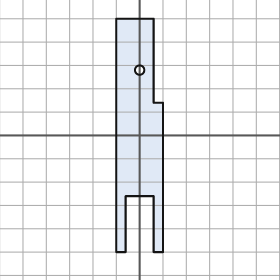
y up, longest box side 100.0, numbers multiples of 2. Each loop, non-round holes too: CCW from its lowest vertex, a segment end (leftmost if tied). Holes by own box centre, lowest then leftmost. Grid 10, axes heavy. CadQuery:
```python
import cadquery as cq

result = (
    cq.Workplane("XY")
    .moveTo(-10.0, -50.0)
    .lineTo(-6.0, -50.0)
    .lineTo(-6.0, -26.0)
    .lineTo(6.0, -26.0)
    .lineTo(6.0, -50.0)
    .lineTo(10.0, -50.0)
    .lineTo(10.0, 14.0)
    .lineTo(6.0, 14.0)
    .lineTo(6.0, 50.0)
    .lineTo(-10.0, 50.0)
    .close()
    .moveTo(0.0, 28.0)
    .circle(2.0)
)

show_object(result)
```